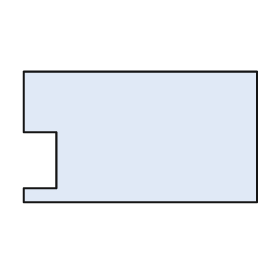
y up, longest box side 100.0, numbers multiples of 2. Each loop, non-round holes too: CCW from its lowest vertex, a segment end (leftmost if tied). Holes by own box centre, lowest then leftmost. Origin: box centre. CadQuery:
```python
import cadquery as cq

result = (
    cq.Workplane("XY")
    .moveTo(-50.0, -28.0)
    .lineTo(50.0, -28.0)
    .lineTo(50.0, 28.0)
    .lineTo(-50.0, 28.0)
    .lineTo(-50.0, 2.0)
    .lineTo(-36.0, 2.0)
    .lineTo(-36.0, -22.0)
    .lineTo(-50.0, -22.0)
    .close()
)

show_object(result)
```